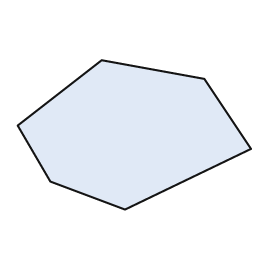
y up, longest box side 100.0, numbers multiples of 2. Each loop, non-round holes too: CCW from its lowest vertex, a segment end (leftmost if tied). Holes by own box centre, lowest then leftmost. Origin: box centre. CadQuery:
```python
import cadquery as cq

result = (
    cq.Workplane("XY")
    .moveTo(-4.0, -32.0)
    .lineTo(50.0, -6.0)
    .lineTo(30.0, 24.0)
    .lineTo(-14.0, 32.0)
    .lineTo(-50.0, 4.0)
    .lineTo(-36.0, -20.0)
    .close()
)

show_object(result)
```